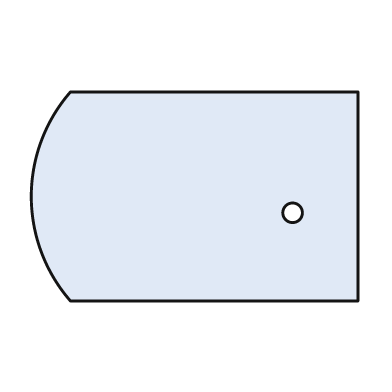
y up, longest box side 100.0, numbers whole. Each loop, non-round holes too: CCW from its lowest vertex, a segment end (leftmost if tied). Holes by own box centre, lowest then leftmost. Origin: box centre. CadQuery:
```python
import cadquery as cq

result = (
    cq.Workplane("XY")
    .moveTo(-38.0, -32.0)
    .lineTo(50.0, -32.0)
    .lineTo(50.0, 32.0)
    .lineTo(-38.0, 32.0)
    .threePointArc((-50.0, 0.0), (-38.0, -32.0))
    .close()
    .moveTo(30.0, -5.0)
    .circle(3.0)
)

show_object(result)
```